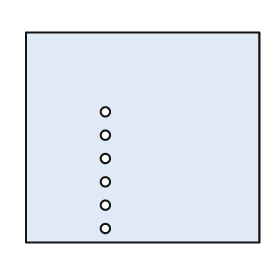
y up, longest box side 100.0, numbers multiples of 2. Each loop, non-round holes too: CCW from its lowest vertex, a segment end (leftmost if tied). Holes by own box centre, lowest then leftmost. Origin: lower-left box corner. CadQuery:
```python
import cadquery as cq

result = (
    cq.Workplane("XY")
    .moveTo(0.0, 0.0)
    .lineTo(100.0, 0.0)
    .lineTo(100.0, 90.0)
    .lineTo(0.0, 90.0)
    .close()
    .moveTo(34.0, 6.0)
    .circle(2.0)
    .moveTo(34.0, 16.0)
    .circle(2.0)
    .moveTo(34.0, 26.0)
    .circle(2.0)
    .moveTo(34.0, 36.0)
    .circle(2.0)
    .moveTo(34.0, 46.0)
    .circle(2.0)
    .moveTo(34.0, 56.0)
    .circle(2.0)
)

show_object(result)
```